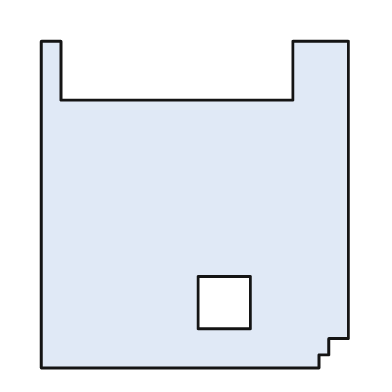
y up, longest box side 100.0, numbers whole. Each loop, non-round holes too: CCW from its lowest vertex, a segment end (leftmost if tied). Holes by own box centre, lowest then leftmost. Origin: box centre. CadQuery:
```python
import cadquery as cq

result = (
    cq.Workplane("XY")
    .moveTo(-47.0, -50.0)
    .lineTo(38.0, -50.0)
    .lineTo(38.0, -46.0)
    .lineTo(41.0, -46.0)
    .lineTo(41.0, -41.0)
    .lineTo(47.0, -41.0)
    .lineTo(47.0, 50.0)
    .lineTo(30.0, 50.0)
    .lineTo(30.0, 32.0)
    .lineTo(-41.0, 32.0)
    .lineTo(-41.0, 50.0)
    .lineTo(-47.0, 50.0)
    .close()
    .moveTo(1.0, -38.0)
    .lineTo(17.0, -38.0)
    .lineTo(17.0, -22.0)
    .lineTo(1.0, -22.0)
    .close()
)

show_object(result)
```